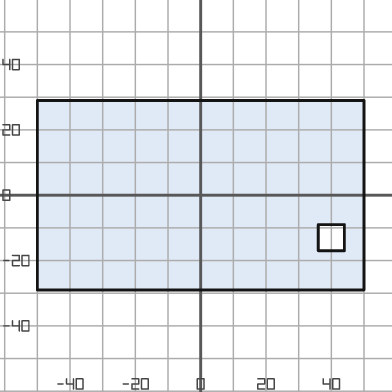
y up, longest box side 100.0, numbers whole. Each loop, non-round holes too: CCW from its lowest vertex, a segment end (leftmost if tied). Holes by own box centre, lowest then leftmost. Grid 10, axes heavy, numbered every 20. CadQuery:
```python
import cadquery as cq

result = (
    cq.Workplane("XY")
    .moveTo(-50.0, -29.0)
    .lineTo(50.0, -29.0)
    .lineTo(50.0, 29.0)
    .lineTo(-50.0, 29.0)
    .close()
    .moveTo(36.0, -17.0)
    .lineTo(44.0, -17.0)
    .lineTo(44.0, -9.0)
    .lineTo(36.0, -9.0)
    .close()
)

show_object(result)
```